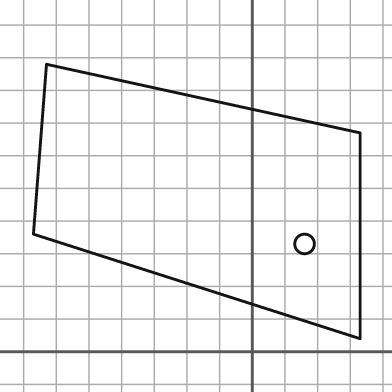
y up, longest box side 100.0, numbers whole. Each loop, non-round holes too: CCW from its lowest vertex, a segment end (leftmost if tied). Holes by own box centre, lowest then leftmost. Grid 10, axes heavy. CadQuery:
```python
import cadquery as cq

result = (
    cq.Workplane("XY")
    .moveTo(33.0, 4.0)
    .lineTo(33.0, 67.0)
    .lineTo(-63.0, 88.0)
    .lineTo(-67.0, 36.0)
    .close()
    .moveTo(16.0, 33.0)
    .circle(3.0)
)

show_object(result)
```